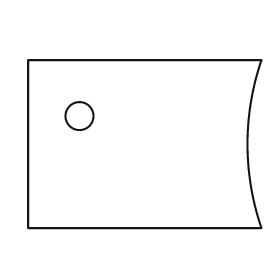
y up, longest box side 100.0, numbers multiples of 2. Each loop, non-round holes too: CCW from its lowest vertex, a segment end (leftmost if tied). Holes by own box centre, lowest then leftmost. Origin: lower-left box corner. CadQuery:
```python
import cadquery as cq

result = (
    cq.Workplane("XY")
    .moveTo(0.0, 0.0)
    .lineTo(100.0, 0.0)
    .threePointArc((94.0, 36.0), (100.0, 72.0))
    .lineTo(0.0, 72.0)
    .close()
    .moveTo(22.0, 48.0)
    .circle(6.0)
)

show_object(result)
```